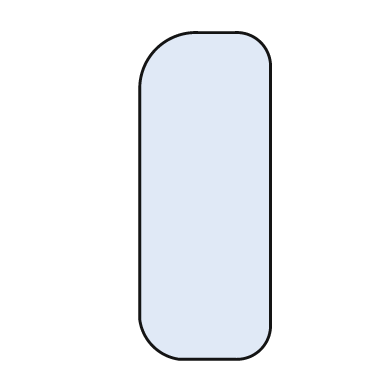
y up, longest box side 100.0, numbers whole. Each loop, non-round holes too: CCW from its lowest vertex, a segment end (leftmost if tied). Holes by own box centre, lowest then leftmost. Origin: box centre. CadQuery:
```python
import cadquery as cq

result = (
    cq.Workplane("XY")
    .moveTo(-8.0, -50.0)
    .lineTo(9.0, -50.0)
    .threePointArc((17.0, -47.0), (20.0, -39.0))
    .lineTo(20.0, 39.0)
    .threePointArc((17.0, 47.0), (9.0, 50.0))
    .lineTo(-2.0, 50.0)
    .threePointArc((-15.0, 45.0), (-20.0, 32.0))
    .lineTo(-20.0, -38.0)
    .threePointArc((-16.0, -46.0), (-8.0, -50.0))
    .close()
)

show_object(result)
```